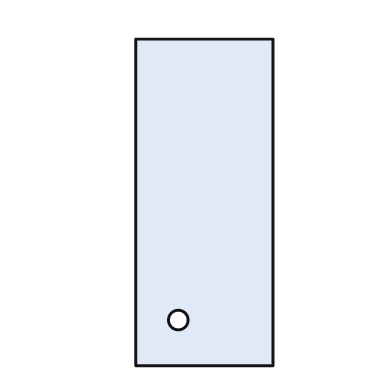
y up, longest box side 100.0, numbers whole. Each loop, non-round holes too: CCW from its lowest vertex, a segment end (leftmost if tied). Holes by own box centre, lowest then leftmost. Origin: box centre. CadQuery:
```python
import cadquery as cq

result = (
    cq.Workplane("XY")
    .moveTo(-21.0, -50.0)
    .lineTo(21.0, -50.0)
    .lineTo(21.0, 50.0)
    .lineTo(-21.0, 50.0)
    .close()
    .moveTo(-8.0, -36.0)
    .circle(3.0)
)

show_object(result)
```